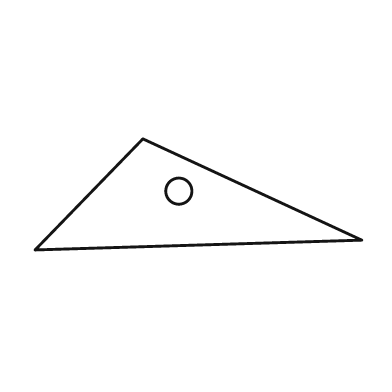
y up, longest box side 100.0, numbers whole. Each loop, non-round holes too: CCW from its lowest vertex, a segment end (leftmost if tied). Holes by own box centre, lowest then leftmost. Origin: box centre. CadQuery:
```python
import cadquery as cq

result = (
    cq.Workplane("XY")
    .moveTo(-50.0, -17.0)
    .lineTo(50.0, -14.0)
    .lineTo(-17.0, 17.0)
    .close()
    .moveTo(-6.0, 1.0)
    .circle(4.0)
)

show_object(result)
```